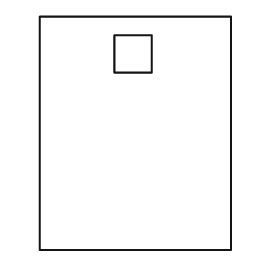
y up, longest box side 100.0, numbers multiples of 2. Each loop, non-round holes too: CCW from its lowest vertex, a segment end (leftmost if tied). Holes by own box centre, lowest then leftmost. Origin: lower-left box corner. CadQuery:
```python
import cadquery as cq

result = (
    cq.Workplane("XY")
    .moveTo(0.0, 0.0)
    .lineTo(82.0, 0.0)
    .lineTo(82.0, 100.0)
    .lineTo(0.0, 100.0)
    .close()
    .moveTo(32.0, 76.0)
    .lineTo(48.0, 76.0)
    .lineTo(48.0, 92.0)
    .lineTo(32.0, 92.0)
    .close()
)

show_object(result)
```